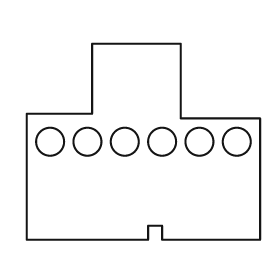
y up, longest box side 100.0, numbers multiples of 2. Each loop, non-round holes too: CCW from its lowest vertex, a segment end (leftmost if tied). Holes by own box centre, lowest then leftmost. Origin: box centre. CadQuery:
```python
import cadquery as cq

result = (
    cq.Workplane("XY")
    .moveTo(-50.0, -42.0)
    .lineTo(2.0, -42.0)
    .lineTo(2.0, -36.0)
    .lineTo(8.0, -36.0)
    .lineTo(8.0, -42.0)
    .lineTo(50.0, -42.0)
    .lineTo(50.0, 10.0)
    .lineTo(16.0, 10.0)
    .lineTo(16.0, 42.0)
    .lineTo(-22.0, 42.0)
    .lineTo(-22.0, 12.0)
    .lineTo(-50.0, 12.0)
    .close()
    .moveTo(-40.0, 0.0)
    .circle(6.0)
    .moveTo(-24.0, 0.0)
    .circle(6.0)
    .moveTo(-8.0, 0.0)
    .circle(6.0)
    .moveTo(8.0, 0.0)
    .circle(6.0)
    .moveTo(24.0, 0.0)
    .circle(6.0)
    .moveTo(40.0, 0.0)
    .circle(6.0)
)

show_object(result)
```